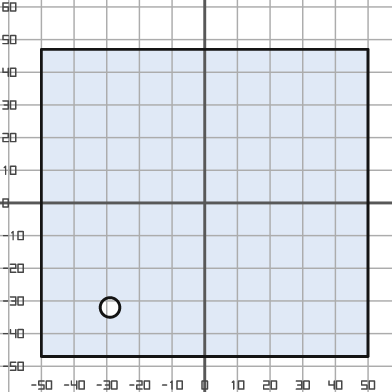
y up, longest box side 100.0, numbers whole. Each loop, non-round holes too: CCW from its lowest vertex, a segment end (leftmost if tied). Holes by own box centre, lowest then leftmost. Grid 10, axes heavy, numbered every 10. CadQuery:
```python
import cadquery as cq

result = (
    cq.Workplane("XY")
    .moveTo(-50.0, -47.0)
    .lineTo(50.0, -47.0)
    .lineTo(50.0, 47.0)
    .lineTo(-50.0, 47.0)
    .close()
    .moveTo(-29.0, -32.0)
    .circle(3.0)
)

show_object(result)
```